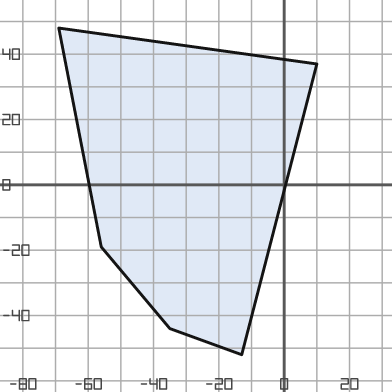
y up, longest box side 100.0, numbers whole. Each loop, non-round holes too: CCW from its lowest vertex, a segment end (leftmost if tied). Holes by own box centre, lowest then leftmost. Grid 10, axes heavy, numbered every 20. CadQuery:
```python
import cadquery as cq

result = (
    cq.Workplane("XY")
    .moveTo(-13.0, -52.0)
    .lineTo(10.0, 37.0)
    .lineTo(-69.0, 48.0)
    .lineTo(-56.0, -19.0)
    .lineTo(-35.0, -44.0)
    .close()
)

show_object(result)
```